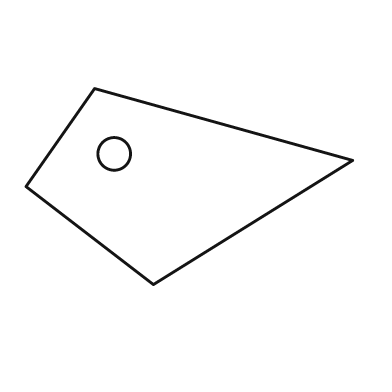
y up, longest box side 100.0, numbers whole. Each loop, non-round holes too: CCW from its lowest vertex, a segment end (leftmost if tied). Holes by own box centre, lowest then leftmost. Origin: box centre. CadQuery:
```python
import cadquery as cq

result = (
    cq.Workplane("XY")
    .moveTo(-11.0, -30.0)
    .lineTo(50.0, 8.0)
    .lineTo(-29.0, 30.0)
    .lineTo(-50.0, 0.0)
    .close()
    .moveTo(-23.0, 10.0)
    .circle(5.0)
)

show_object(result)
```